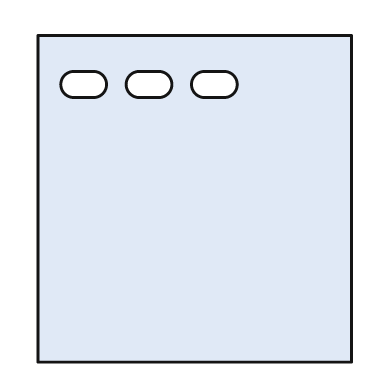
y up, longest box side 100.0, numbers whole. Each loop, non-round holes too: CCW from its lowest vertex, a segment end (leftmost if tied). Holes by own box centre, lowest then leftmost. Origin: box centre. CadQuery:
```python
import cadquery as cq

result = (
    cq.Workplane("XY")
    .moveTo(-48.0, -50.0)
    .lineTo(48.0, -50.0)
    .lineTo(48.0, 50.0)
    .lineTo(-48.0, 50.0)
    .close()
    .moveTo(-37.0, 31.0)
    .lineTo(-31.0, 31.0)
    .threePointArc((-27.0, 35.0), (-31.0, 39.0))
    .lineTo(-37.0, 39.0)
    .threePointArc((-41.0, 35.0), (-37.0, 31.0))
    .close()
    .moveTo(-17.0, 31.0)
    .lineTo(-11.0, 31.0)
    .threePointArc((-7.0, 35.0), (-11.0, 39.0))
    .lineTo(-17.0, 39.0)
    .threePointArc((-21.0, 35.0), (-17.0, 31.0))
    .close()
    .moveTo(3.0, 31.0)
    .lineTo(9.0, 31.0)
    .threePointArc((13.0, 35.0), (9.0, 39.0))
    .lineTo(3.0, 39.0)
    .threePointArc((-1.0, 35.0), (3.0, 31.0))
    .close()
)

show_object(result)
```